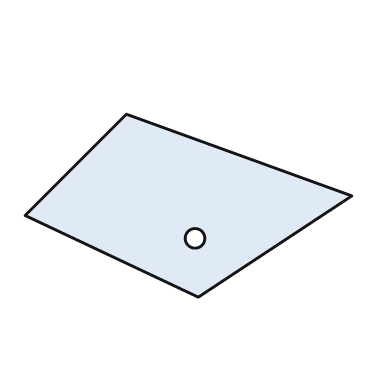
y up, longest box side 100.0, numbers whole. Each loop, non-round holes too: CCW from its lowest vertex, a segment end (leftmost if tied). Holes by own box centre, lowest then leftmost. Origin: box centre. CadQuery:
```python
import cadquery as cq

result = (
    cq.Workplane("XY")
    .moveTo(3.0, -28.0)
    .lineTo(50.0, 3.0)
    .lineTo(-19.0, 28.0)
    .lineTo(-50.0, -3.0)
    .close()
    .moveTo(2.0, -10.0)
    .circle(3.0)
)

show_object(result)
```